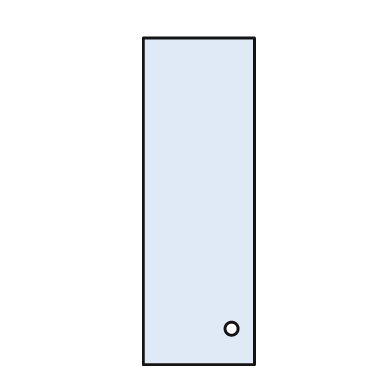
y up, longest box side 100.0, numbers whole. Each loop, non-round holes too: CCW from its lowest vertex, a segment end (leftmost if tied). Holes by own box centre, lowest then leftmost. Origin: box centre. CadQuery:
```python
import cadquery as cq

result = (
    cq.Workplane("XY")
    .moveTo(-17.0, -50.0)
    .lineTo(17.0, -50.0)
    .lineTo(17.0, 50.0)
    .lineTo(-17.0, 50.0)
    .close()
    .moveTo(10.0, -39.0)
    .circle(2.0)
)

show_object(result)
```